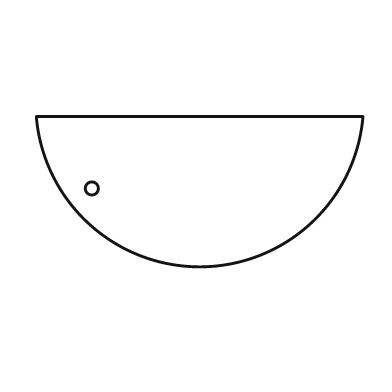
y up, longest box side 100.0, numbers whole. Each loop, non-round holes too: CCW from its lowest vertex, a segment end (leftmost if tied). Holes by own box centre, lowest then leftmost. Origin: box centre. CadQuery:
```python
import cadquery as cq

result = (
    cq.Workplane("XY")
    .moveTo(-50.0, 23.0)
    .threePointArc((0.0, -23.0), (50.0, 23.0))
    .close()
    .moveTo(-33.0, 1.0)
    .circle(2.0)
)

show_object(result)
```